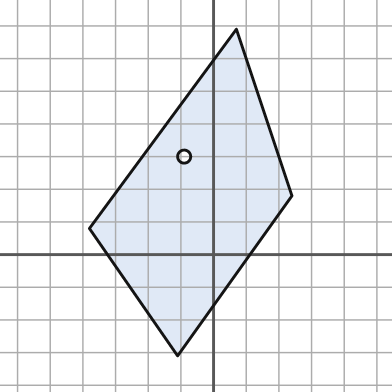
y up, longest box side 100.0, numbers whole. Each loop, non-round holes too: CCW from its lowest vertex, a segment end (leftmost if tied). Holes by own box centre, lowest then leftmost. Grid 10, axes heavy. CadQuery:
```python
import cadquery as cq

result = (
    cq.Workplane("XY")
    .moveTo(-11.0, -31.0)
    .lineTo(24.0, 18.0)
    .lineTo(7.0, 69.0)
    .lineTo(-38.0, 8.0)
    .close()
    .moveTo(-9.0, 30.0)
    .circle(2.0)
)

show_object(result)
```